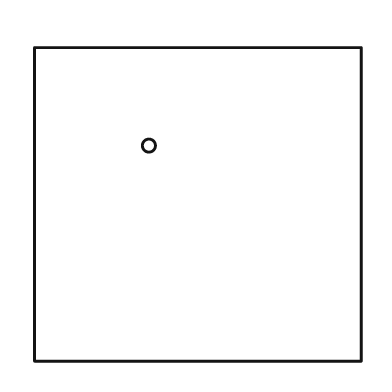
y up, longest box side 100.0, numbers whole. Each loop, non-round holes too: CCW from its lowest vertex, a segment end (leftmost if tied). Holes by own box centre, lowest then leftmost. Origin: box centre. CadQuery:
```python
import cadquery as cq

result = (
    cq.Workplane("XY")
    .moveTo(-50.0, -48.0)
    .lineTo(50.0, -48.0)
    .lineTo(50.0, 48.0)
    .lineTo(-50.0, 48.0)
    .close()
    .moveTo(-15.0, 18.0)
    .circle(2.0)
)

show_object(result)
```